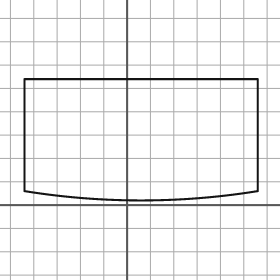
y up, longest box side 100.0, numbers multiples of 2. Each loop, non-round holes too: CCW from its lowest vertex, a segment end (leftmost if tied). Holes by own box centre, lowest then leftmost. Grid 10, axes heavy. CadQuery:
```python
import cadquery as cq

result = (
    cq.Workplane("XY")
    .moveTo(-44.0, 6.0)
    .threePointArc((6.0, 2.0), (56.0, 6.0))
    .lineTo(56.0, 54.0)
    .lineTo(-44.0, 54.0)
    .close()
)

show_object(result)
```